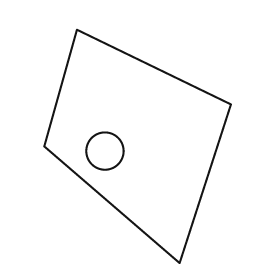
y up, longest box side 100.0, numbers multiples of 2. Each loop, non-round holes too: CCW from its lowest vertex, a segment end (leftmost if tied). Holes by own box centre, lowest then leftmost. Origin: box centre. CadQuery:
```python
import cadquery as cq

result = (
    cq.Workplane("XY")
    .moveTo(18.0, -50.0)
    .lineTo(40.0, 18.0)
    .lineTo(-26.0, 50.0)
    .lineTo(-40.0, 0.0)
    .close()
    .moveTo(-14.0, -2.0)
    .circle(8.0)
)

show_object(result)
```